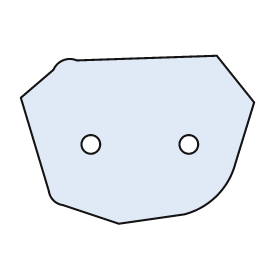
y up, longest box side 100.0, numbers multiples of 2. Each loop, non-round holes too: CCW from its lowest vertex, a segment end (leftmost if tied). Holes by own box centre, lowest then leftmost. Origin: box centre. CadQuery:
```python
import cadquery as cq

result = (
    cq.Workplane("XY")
    .moveTo(-8.0, -36.0)
    .lineTo(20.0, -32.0)
    .threePointArc((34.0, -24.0), (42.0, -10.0))
    .lineTo(50.0, 16.0)
    .lineTo(34.0, 36.0)
    .lineTo(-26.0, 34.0)
    .threePointArc((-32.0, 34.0), (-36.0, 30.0))
    .lineTo(-50.0, 18.0)
    .lineTo(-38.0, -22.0)
    .threePointArc((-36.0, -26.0), (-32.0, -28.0))
    .close()
    .moveTo(-20.0, -2.0)
    .circle(4.0)
    .moveTo(22.0, -2.0)
    .circle(4.0)
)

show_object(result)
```